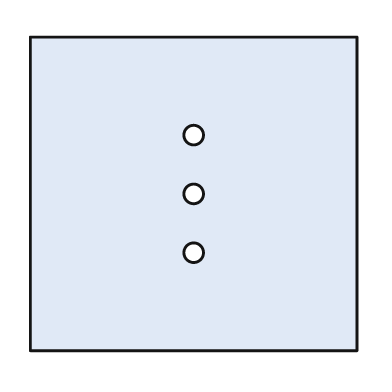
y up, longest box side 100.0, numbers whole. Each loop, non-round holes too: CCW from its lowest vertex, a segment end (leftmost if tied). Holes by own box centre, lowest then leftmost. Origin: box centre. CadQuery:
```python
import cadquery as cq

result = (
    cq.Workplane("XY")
    .moveTo(-50.0, -48.0)
    .lineTo(50.0, -48.0)
    .lineTo(50.0, 48.0)
    .lineTo(-50.0, 48.0)
    .close()
    .moveTo(0.0, -18.0)
    .circle(3.0)
    .moveTo(0.0, 0.0)
    .circle(3.0)
    .moveTo(0.0, 18.0)
    .circle(3.0)
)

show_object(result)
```